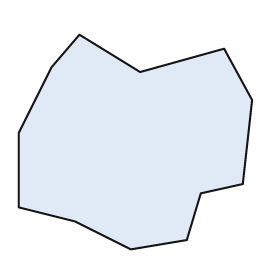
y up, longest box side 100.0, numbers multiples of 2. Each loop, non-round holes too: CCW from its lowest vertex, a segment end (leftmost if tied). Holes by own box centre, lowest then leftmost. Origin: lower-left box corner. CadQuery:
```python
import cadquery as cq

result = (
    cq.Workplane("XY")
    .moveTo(48.0, 0.0)
    .lineTo(72.0, 4.0)
    .lineTo(78.0, 24.0)
    .lineTo(96.0, 28.0)
    .lineTo(100.0, 64.0)
    .lineTo(88.0, 86.0)
    .lineTo(52.0, 76.0)
    .lineTo(26.0, 92.0)
    .lineTo(14.0, 78.0)
    .lineTo(0.0, 50.0)
    .lineTo(0.0, 18.0)
    .lineTo(24.0, 12.0)
    .close()
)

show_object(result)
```